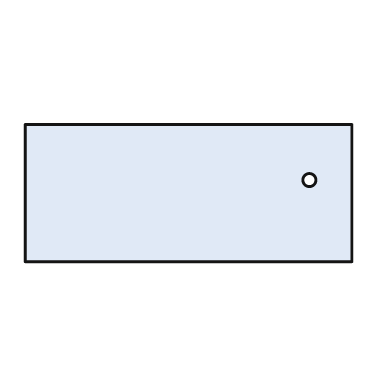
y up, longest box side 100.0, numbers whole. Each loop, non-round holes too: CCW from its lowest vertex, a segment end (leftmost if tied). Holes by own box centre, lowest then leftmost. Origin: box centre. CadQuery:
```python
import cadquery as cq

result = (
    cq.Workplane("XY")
    .moveTo(-50.0, -21.0)
    .lineTo(50.0, -21.0)
    .lineTo(50.0, 21.0)
    .lineTo(-50.0, 21.0)
    .close()
    .moveTo(37.0, 4.0)
    .circle(2.0)
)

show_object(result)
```